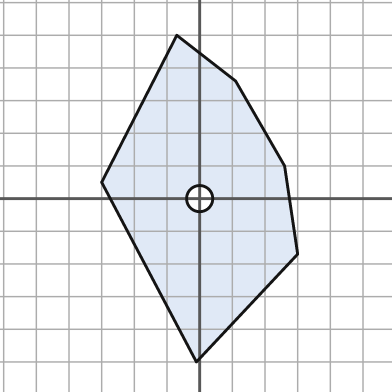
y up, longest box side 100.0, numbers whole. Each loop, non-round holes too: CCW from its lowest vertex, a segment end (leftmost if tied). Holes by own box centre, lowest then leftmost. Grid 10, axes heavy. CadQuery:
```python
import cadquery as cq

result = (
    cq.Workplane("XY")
    .moveTo(-1.0, -50.0)
    .lineTo(30.0, -17.0)
    .lineTo(26.0, 10.0)
    .lineTo(11.0, 36.0)
    .lineTo(-7.0, 50.0)
    .lineTo(-30.0, 5.0)
    .close()
    .moveTo(0.0, 0.0)
    .circle(4.0)
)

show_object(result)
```